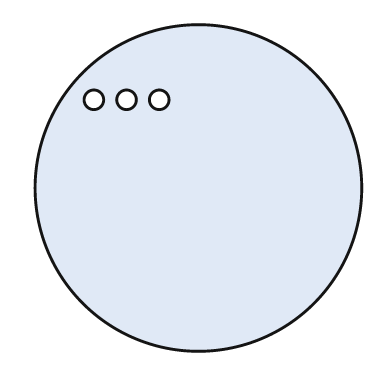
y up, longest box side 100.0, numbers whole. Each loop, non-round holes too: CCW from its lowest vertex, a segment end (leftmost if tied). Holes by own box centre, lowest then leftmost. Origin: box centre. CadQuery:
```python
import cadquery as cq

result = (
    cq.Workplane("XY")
    .moveTo(0.0, 0.0)
    .circle(50.0)
    .moveTo(-32.0, 27.0)
    .circle(3.0)
    .moveTo(-22.0, 27.0)
    .circle(3.0)
    .moveTo(-12.0, 27.0)
    .circle(3.0)
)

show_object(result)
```